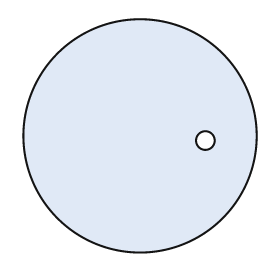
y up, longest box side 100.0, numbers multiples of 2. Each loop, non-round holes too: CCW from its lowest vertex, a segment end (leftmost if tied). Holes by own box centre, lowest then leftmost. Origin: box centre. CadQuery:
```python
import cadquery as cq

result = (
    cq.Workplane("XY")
    .moveTo(0.0, 0.0)
    .circle(50.0)
    .moveTo(28.0, -2.0)
    .circle(4.0)
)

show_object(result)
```